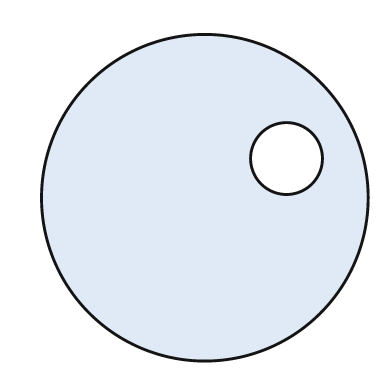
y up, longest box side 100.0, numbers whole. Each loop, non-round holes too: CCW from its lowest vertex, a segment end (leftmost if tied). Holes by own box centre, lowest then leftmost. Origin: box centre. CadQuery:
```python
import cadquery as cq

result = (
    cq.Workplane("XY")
    .moveTo(0.0, 0.0)
    .circle(50.0)
    .moveTo(25.0, 12.0)
    .circle(11.0)
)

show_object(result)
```